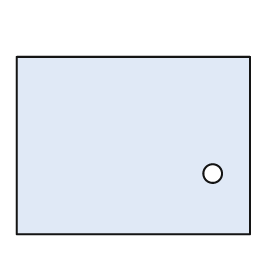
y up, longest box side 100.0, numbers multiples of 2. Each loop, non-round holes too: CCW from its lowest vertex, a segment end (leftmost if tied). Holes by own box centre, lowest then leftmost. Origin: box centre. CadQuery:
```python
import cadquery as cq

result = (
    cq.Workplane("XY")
    .moveTo(-50.0, -38.0)
    .lineTo(50.0, -38.0)
    .lineTo(50.0, 38.0)
    .lineTo(-50.0, 38.0)
    .close()
    .moveTo(34.0, -12.0)
    .circle(4.0)
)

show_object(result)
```